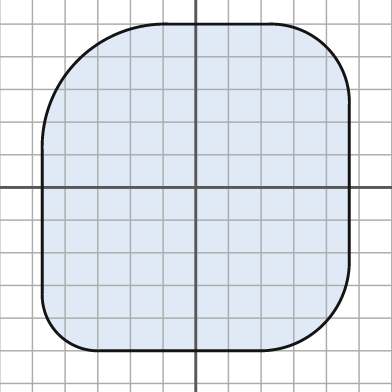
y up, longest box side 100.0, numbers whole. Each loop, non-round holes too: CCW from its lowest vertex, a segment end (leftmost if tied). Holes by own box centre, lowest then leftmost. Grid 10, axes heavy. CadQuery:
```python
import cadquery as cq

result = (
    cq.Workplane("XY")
    .moveTo(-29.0, -50.0)
    .lineTo(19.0, -50.0)
    .threePointArc((39.0, -42.0), (47.0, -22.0))
    .lineTo(47.0, 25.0)
    .threePointArc((40.0, 43.0), (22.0, 50.0))
    .lineTo(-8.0, 50.0)
    .threePointArc((-36.0, 39.0), (-47.0, 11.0))
    .lineTo(-47.0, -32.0)
    .threePointArc((-42.0, -45.0), (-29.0, -50.0))
    .close()
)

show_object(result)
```